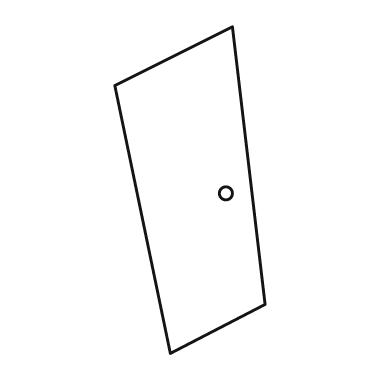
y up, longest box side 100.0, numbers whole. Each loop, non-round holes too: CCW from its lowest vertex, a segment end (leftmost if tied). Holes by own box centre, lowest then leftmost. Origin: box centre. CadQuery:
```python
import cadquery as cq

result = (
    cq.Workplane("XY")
    .moveTo(-6.0, -50.0)
    .lineTo(23.0, -35.0)
    .lineTo(13.0, 50.0)
    .lineTo(-23.0, 32.0)
    .close()
    .moveTo(11.0, -1.0)
    .circle(2.0)
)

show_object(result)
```